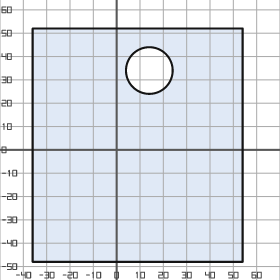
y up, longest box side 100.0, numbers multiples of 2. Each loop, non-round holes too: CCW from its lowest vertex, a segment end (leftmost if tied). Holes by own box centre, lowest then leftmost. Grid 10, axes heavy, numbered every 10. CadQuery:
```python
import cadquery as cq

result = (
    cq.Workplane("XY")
    .moveTo(-36.0, -48.0)
    .lineTo(54.0, -48.0)
    .lineTo(54.0, 52.0)
    .lineTo(-36.0, 52.0)
    .close()
    .moveTo(14.0, 34.0)
    .circle(10.0)
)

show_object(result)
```